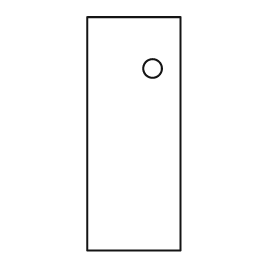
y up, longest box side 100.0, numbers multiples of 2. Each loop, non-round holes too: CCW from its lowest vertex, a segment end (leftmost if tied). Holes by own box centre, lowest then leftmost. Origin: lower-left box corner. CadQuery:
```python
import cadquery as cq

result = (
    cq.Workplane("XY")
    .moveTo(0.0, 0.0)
    .lineTo(40.0, 0.0)
    .lineTo(40.0, 100.0)
    .lineTo(0.0, 100.0)
    .close()
    .moveTo(28.0, 78.0)
    .circle(4.0)
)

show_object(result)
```